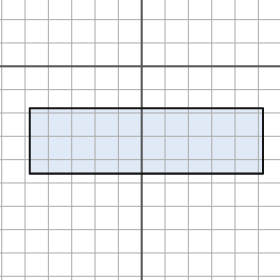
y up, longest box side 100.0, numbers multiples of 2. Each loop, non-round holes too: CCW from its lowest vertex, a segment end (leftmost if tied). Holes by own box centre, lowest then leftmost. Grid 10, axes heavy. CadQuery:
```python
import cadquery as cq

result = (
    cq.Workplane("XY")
    .moveTo(-48.0, -46.0)
    .lineTo(52.0, -46.0)
    .lineTo(52.0, -18.0)
    .lineTo(-48.0, -18.0)
    .close()
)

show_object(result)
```